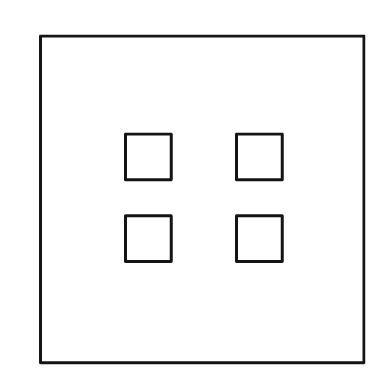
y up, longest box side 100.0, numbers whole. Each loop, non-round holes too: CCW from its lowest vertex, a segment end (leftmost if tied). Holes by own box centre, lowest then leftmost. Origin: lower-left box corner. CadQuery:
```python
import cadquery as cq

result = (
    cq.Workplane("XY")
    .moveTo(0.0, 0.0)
    .lineTo(99.0, 0.0)
    .lineTo(99.0, 100.0)
    .lineTo(0.0, 100.0)
    .close()
    .moveTo(26.0, 31.0)
    .lineTo(40.0, 31.0)
    .lineTo(40.0, 45.0)
    .lineTo(26.0, 45.0)
    .close()
    .moveTo(60.0, 31.0)
    .lineTo(74.0, 31.0)
    .lineTo(74.0, 45.0)
    .lineTo(60.0, 45.0)
    .close()
    .moveTo(26.0, 56.0)
    .lineTo(40.0, 56.0)
    .lineTo(40.0, 70.0)
    .lineTo(26.0, 70.0)
    .close()
    .moveTo(60.0, 56.0)
    .lineTo(74.0, 56.0)
    .lineTo(74.0, 70.0)
    .lineTo(60.0, 70.0)
    .close()
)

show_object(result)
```